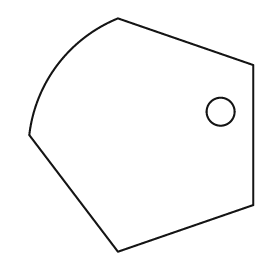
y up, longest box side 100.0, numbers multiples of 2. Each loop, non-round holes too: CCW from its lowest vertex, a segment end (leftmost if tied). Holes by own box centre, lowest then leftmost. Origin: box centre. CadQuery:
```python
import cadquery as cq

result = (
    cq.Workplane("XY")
    .moveTo(-10.0, -50.0)
    .lineTo(48.0, -30.0)
    .lineTo(48.0, 30.0)
    .lineTo(-10.0, 50.0)
    .threePointArc((-36.0, 30.0), (-48.0, 0.0))
    .close()
    .moveTo(34.0, 10.0)
    .circle(6.0)
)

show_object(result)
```